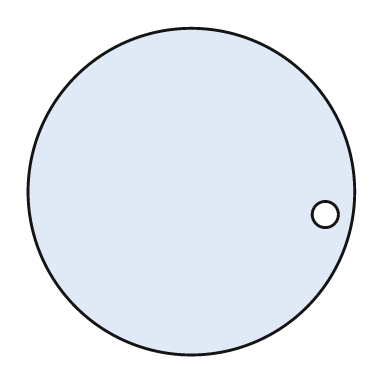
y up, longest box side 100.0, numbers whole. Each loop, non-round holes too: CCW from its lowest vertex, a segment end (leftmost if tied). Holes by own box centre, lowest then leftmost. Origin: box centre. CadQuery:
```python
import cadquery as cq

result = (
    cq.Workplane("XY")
    .moveTo(0.0, 0.0)
    .circle(50.0)
    .moveTo(41.0, -7.0)
    .circle(4.0)
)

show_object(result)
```